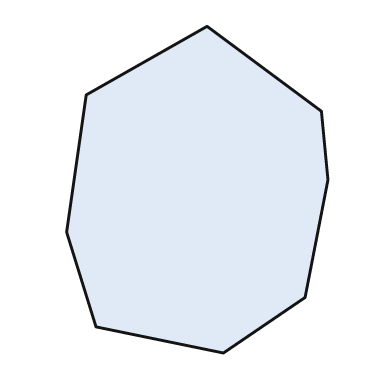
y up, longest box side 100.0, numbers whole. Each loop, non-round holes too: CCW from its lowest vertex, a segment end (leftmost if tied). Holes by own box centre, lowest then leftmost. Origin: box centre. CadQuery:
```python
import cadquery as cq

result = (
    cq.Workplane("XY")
    .moveTo(8.0, -50.0)
    .lineTo(33.0, -33.0)
    .lineTo(40.0, 3.0)
    .lineTo(38.0, 24.0)
    .lineTo(3.0, 50.0)
    .lineTo(-34.0, 29.0)
    .lineTo(-40.0, -13.0)
    .lineTo(-31.0, -42.0)
    .close()
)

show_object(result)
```